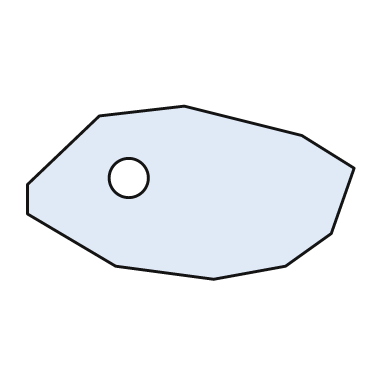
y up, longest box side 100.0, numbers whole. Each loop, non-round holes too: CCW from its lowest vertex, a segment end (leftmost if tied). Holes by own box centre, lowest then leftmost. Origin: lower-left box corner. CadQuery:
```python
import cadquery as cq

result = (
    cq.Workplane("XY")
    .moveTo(57.0, 0.0)
    .lineTo(79.0, 4.0)
    .lineTo(93.0, 14.0)
    .lineTo(100.0, 34.0)
    .lineTo(84.0, 44.0)
    .lineTo(48.0, 53.0)
    .lineTo(22.0, 50.0)
    .lineTo(0.0, 29.0)
    .lineTo(0.0, 20.0)
    .lineTo(27.0, 4.0)
    .close()
    .moveTo(31.0, 31.0)
    .circle(6.0)
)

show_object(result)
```